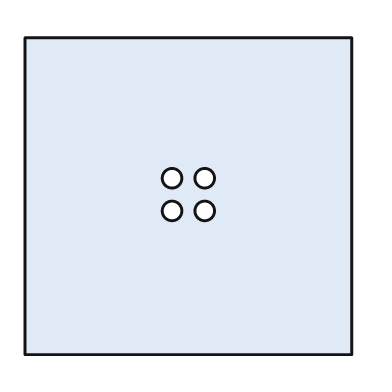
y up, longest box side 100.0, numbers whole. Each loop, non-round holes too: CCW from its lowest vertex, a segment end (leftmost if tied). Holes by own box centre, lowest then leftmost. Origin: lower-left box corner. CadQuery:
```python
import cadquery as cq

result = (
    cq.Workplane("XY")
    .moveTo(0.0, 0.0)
    .lineTo(100.0, 0.0)
    .lineTo(100.0, 97.0)
    .lineTo(0.0, 97.0)
    .close()
    .moveTo(45.0, 44.0)
    .circle(3.0)
    .moveTo(55.0, 44.0)
    .circle(3.0)
    .moveTo(45.0, 54.0)
    .circle(3.0)
    .moveTo(55.0, 54.0)
    .circle(3.0)
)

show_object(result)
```